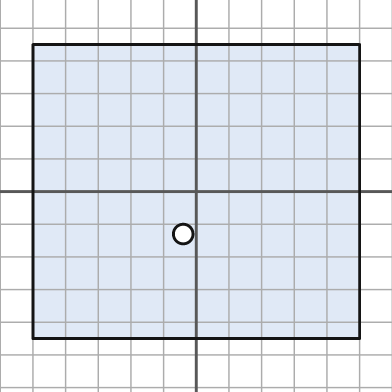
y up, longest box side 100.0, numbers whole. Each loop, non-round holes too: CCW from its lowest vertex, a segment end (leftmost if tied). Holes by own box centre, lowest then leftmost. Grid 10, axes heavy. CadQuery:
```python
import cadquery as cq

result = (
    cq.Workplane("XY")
    .moveTo(-50.0, -45.0)
    .lineTo(50.0, -45.0)
    .lineTo(50.0, 45.0)
    .lineTo(-50.0, 45.0)
    .close()
    .moveTo(-4.0, -13.0)
    .circle(3.0)
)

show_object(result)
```